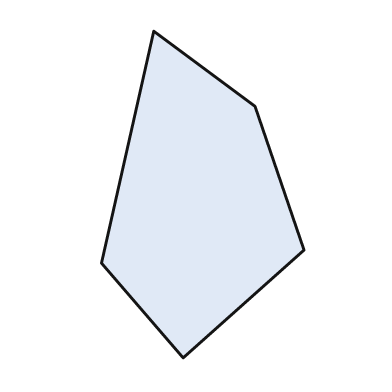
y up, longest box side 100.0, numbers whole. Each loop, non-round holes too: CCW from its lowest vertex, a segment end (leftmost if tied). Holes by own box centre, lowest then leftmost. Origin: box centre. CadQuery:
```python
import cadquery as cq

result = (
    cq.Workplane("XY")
    .moveTo(-6.0, -50.0)
    .lineTo(31.0, -17.0)
    .lineTo(16.0, 27.0)
    .lineTo(-15.0, 50.0)
    .lineTo(-31.0, -21.0)
    .close()
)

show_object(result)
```